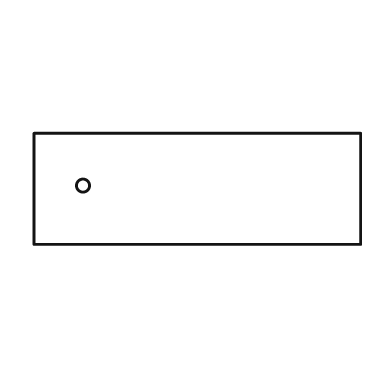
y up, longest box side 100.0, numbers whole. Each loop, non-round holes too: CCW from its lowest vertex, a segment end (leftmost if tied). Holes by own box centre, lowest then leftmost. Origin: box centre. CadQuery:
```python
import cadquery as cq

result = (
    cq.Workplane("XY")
    .moveTo(-50.0, -17.0)
    .lineTo(50.0, -17.0)
    .lineTo(50.0, 17.0)
    .lineTo(-50.0, 17.0)
    .close()
    .moveTo(-35.0, 1.0)
    .circle(2.0)
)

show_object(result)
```